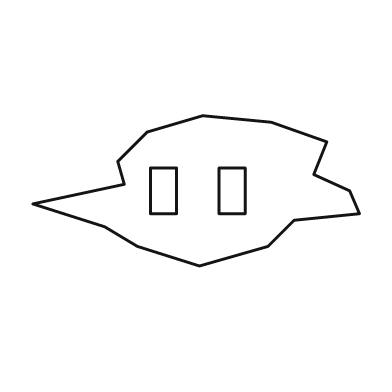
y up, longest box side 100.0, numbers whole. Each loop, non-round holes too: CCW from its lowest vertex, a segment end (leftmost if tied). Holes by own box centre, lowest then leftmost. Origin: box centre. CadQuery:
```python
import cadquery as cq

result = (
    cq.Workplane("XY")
    .moveTo(1.0, -23.0)
    .lineTo(22.0, -17.0)
    .lineTo(30.0, -9.0)
    .lineTo(50.0, -7.0)
    .lineTo(47.0, 0.0)
    .lineTo(36.0, 5.0)
    .lineTo(40.0, 15.0)
    .lineTo(23.0, 21.0)
    .lineTo(2.0, 23.0)
    .lineTo(-15.0, 18.0)
    .lineTo(-24.0, 9.0)
    .lineTo(-22.0, 2.0)
    .lineTo(-50.0, -4.0)
    .lineTo(-28.0, -11.0)
    .lineTo(-18.0, -17.0)
    .close()
    .moveTo(-14.0, -7.0)
    .lineTo(-6.0, -7.0)
    .lineTo(-6.0, 7.0)
    .lineTo(-14.0, 7.0)
    .close()
    .moveTo(7.0, -7.0)
    .lineTo(15.0, -7.0)
    .lineTo(15.0, 7.0)
    .lineTo(7.0, 7.0)
    .close()
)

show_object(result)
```